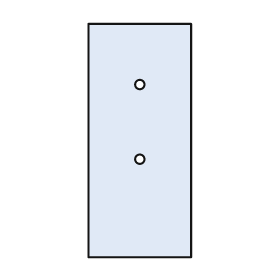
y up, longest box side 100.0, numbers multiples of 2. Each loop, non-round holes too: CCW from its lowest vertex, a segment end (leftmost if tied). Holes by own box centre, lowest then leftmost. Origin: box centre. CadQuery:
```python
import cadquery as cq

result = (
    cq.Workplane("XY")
    .moveTo(-22.0, -50.0)
    .lineTo(22.0, -50.0)
    .lineTo(22.0, 50.0)
    .lineTo(-22.0, 50.0)
    .close()
    .moveTo(0.0, -8.0)
    .circle(2.0)
    .moveTo(0.0, 24.0)
    .circle(2.0)
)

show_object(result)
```